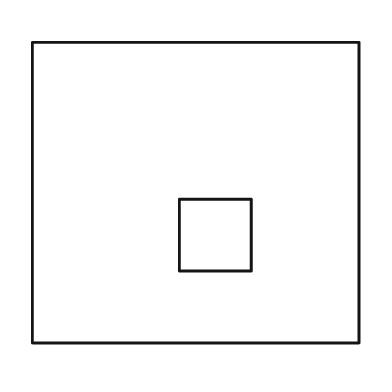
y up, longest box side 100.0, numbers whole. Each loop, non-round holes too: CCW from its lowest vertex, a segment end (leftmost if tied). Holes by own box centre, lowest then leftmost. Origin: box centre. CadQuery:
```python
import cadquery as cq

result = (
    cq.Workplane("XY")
    .moveTo(-50.0, -46.0)
    .lineTo(50.0, -46.0)
    .lineTo(50.0, 46.0)
    .lineTo(-50.0, 46.0)
    .close()
    .moveTo(-5.0, -24.0)
    .lineTo(17.0, -24.0)
    .lineTo(17.0, -2.0)
    .lineTo(-5.0, -2.0)
    .close()
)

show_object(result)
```